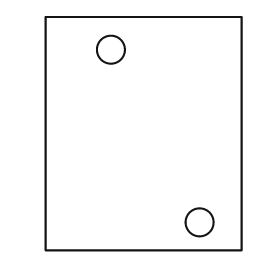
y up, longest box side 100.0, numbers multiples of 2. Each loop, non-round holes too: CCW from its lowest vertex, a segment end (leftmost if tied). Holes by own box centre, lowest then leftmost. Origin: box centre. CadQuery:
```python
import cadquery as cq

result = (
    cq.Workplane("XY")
    .moveTo(-42.0, -50.0)
    .lineTo(42.0, -50.0)
    .lineTo(42.0, 50.0)
    .lineTo(-42.0, 50.0)
    .close()
    .moveTo(24.0, -38.0)
    .circle(6.0)
    .moveTo(-14.0, 36.0)
    .circle(6.0)
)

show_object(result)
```